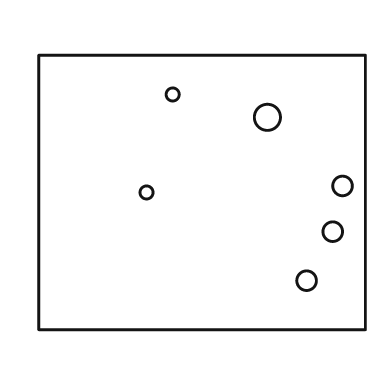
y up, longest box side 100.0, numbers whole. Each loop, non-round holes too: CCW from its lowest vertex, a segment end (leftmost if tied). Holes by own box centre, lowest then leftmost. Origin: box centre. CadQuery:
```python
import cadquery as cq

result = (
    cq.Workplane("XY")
    .moveTo(-50.0, -42.0)
    .lineTo(50.0, -42.0)
    .lineTo(50.0, 42.0)
    .lineTo(-50.0, 42.0)
    .close()
    .moveTo(32.0, -27.0)
    .circle(3.0)
    .moveTo(40.0, -12.0)
    .circle(3.0)
    .moveTo(-17.0, 0.0)
    .circle(2.0)
    .moveTo(43.0, 2.0)
    .circle(3.0)
    .moveTo(20.0, 23.0)
    .circle(4.0)
    .moveTo(-9.0, 30.0)
    .circle(2.0)
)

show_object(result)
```